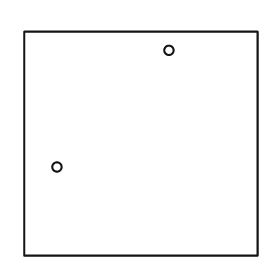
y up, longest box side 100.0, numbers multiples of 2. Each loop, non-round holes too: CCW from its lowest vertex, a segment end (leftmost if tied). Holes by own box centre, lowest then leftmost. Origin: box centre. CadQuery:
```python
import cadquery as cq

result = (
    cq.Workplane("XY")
    .moveTo(-50.0, -48.0)
    .lineTo(50.0, -48.0)
    .lineTo(50.0, 48.0)
    .lineTo(-50.0, 48.0)
    .close()
    .moveTo(-36.0, -10.0)
    .circle(2.0)
    .moveTo(12.0, 40.0)
    .circle(2.0)
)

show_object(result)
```